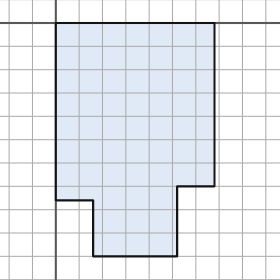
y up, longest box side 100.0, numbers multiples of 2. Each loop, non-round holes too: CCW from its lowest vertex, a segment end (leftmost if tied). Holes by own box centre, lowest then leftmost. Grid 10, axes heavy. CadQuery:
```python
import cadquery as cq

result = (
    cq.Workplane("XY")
    .moveTo(16.0, -100.0)
    .lineTo(52.0, -100.0)
    .lineTo(52.0, -70.0)
    .lineTo(68.0, -70.0)
    .lineTo(68.0, 0.0)
    .lineTo(0.0, 0.0)
    .lineTo(0.0, -76.0)
    .lineTo(16.0, -76.0)
    .close()
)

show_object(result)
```